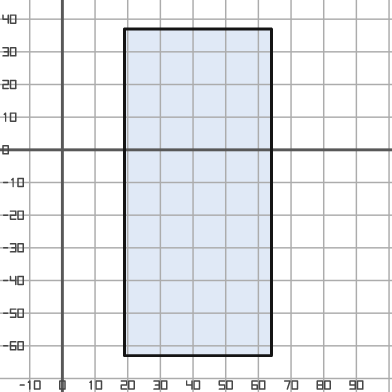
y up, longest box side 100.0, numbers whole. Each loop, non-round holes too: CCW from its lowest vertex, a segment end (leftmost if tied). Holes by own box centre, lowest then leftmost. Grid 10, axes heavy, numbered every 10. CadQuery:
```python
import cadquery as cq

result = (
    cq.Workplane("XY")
    .moveTo(19.0, -63.0)
    .lineTo(64.0, -63.0)
    .lineTo(64.0, 37.0)
    .lineTo(19.0, 37.0)
    .close()
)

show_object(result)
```